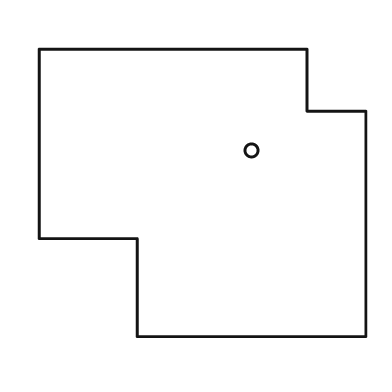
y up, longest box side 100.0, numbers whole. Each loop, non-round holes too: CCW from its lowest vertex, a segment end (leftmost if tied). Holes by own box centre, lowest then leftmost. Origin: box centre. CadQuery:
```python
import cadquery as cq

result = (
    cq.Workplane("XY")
    .moveTo(-20.0, -44.0)
    .lineTo(50.0, -44.0)
    .lineTo(50.0, 25.0)
    .lineTo(32.0, 25.0)
    .lineTo(32.0, 44.0)
    .lineTo(-50.0, 44.0)
    .lineTo(-50.0, -14.0)
    .lineTo(-20.0, -14.0)
    .close()
    .moveTo(15.0, 13.0)
    .circle(2.0)
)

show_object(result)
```